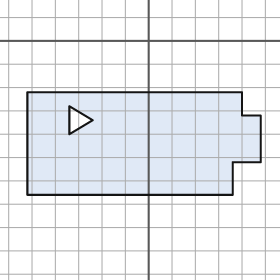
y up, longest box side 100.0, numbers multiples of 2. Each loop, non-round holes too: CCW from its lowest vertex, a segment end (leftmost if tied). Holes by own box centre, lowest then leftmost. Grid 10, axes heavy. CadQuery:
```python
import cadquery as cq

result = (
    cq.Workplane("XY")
    .moveTo(-52.0, -66.0)
    .lineTo(36.0, -66.0)
    .lineTo(36.0, -52.0)
    .lineTo(48.0, -52.0)
    .lineTo(48.0, -32.0)
    .lineTo(40.0, -32.0)
    .lineTo(40.0, -22.0)
    .lineTo(-52.0, -22.0)
    .close()
    .moveTo(-34.0, -40.0)
    .lineTo(-24.0, -34.0)
    .lineTo(-34.0, -28.0)
    .close()
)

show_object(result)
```